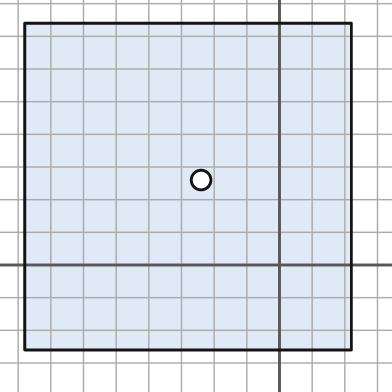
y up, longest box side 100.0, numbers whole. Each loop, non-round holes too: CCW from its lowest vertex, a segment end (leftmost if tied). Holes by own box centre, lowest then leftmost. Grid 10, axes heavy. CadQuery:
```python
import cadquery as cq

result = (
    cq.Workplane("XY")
    .moveTo(-78.0, -26.0)
    .lineTo(22.0, -26.0)
    .lineTo(22.0, 74.0)
    .lineTo(-78.0, 74.0)
    .close()
    .moveTo(-24.0, 26.0)
    .circle(3.0)
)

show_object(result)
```